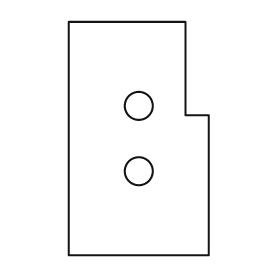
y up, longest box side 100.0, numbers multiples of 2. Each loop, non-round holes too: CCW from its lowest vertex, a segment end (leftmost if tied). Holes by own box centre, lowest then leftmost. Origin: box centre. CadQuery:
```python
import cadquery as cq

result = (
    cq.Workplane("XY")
    .moveTo(-30.0, -50.0)
    .lineTo(30.0, -50.0)
    .lineTo(30.0, 10.0)
    .lineTo(20.0, 10.0)
    .lineTo(20.0, 50.0)
    .lineTo(-30.0, 50.0)
    .close()
    .moveTo(0.0, -14.0)
    .circle(6.0)
    .moveTo(0.0, 14.0)
    .circle(6.0)
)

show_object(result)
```